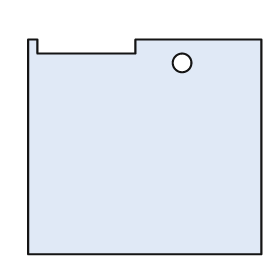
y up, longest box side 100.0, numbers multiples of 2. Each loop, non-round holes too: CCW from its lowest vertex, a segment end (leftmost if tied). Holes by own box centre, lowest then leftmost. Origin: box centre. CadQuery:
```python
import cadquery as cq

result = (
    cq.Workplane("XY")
    .moveTo(-50.0, -46.0)
    .lineTo(50.0, -46.0)
    .lineTo(50.0, 46.0)
    .lineTo(-4.0, 46.0)
    .lineTo(-4.0, 40.0)
    .lineTo(-46.0, 40.0)
    .lineTo(-46.0, 46.0)
    .lineTo(-50.0, 46.0)
    .close()
    .moveTo(16.0, 36.0)
    .circle(4.0)
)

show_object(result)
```